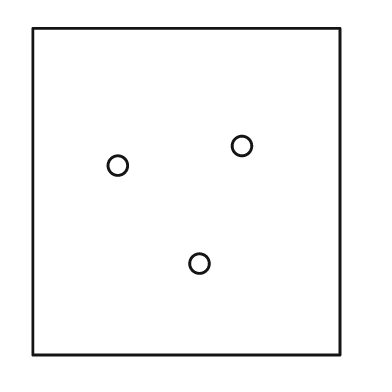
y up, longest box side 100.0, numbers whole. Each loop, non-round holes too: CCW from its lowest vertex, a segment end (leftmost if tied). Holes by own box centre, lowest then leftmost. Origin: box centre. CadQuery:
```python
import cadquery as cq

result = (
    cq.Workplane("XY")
    .moveTo(-47.0, -50.0)
    .lineTo(47.0, -50.0)
    .lineTo(47.0, 50.0)
    .lineTo(-47.0, 50.0)
    .close()
    .moveTo(4.0, -22.0)
    .circle(3.0)
    .moveTo(-21.0, 8.0)
    .circle(3.0)
    .moveTo(17.0, 14.0)
    .circle(3.0)
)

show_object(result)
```